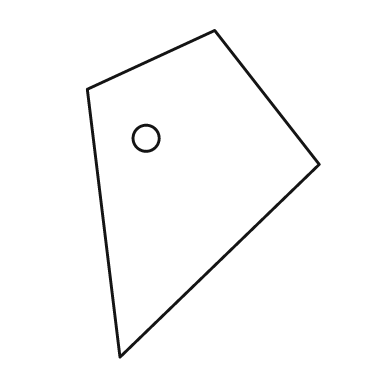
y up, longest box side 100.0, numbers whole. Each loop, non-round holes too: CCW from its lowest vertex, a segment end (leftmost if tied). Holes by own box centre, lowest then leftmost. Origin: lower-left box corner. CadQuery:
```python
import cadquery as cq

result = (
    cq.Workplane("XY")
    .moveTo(10.0, 0.0)
    .lineTo(71.0, 59.0)
    .lineTo(39.0, 100.0)
    .lineTo(0.0, 82.0)
    .close()
    .moveTo(18.0, 67.0)
    .circle(4.0)
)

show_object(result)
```